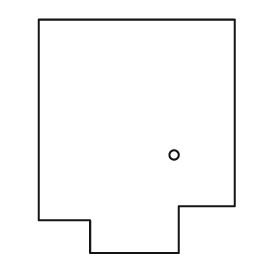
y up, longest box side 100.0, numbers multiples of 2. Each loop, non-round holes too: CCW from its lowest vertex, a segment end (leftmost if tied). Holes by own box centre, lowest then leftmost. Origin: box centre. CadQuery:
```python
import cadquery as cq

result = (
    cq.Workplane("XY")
    .moveTo(-20.0, -50.0)
    .lineTo(18.0, -50.0)
    .lineTo(18.0, -30.0)
    .lineTo(42.0, -30.0)
    .lineTo(42.0, 50.0)
    .lineTo(-42.0, 50.0)
    .lineTo(-42.0, -36.0)
    .lineTo(-20.0, -36.0)
    .close()
    .moveTo(16.0, -8.0)
    .circle(2.0)
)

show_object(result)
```